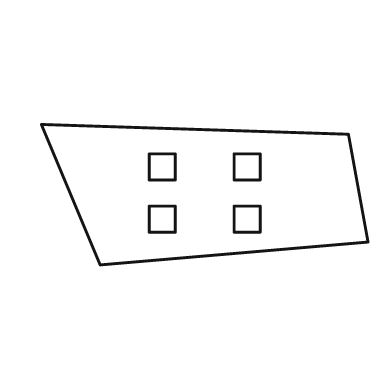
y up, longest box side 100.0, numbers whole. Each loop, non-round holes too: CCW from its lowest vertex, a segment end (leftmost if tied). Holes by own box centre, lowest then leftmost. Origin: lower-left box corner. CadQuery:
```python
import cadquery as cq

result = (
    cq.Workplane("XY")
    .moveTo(18.0, 0.0)
    .lineTo(100.0, 7.0)
    .lineTo(94.0, 40.0)
    .lineTo(0.0, 43.0)
    .close()
    .moveTo(33.0, 10.0)
    .lineTo(41.0, 10.0)
    .lineTo(41.0, 18.0)
    .lineTo(33.0, 18.0)
    .close()
    .moveTo(59.0, 10.0)
    .lineTo(67.0, 10.0)
    .lineTo(67.0, 18.0)
    .lineTo(59.0, 18.0)
    .close()
    .moveTo(33.0, 26.0)
    .lineTo(41.0, 26.0)
    .lineTo(41.0, 34.0)
    .lineTo(33.0, 34.0)
    .close()
    .moveTo(59.0, 26.0)
    .lineTo(67.0, 26.0)
    .lineTo(67.0, 34.0)
    .lineTo(59.0, 34.0)
    .close()
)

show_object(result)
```